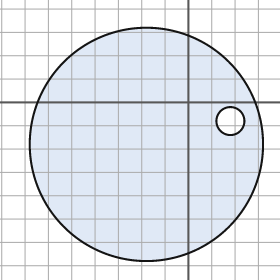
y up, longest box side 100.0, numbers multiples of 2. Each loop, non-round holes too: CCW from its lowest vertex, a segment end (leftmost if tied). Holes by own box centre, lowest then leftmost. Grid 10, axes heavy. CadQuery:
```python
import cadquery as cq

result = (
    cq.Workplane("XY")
    .moveTo(-18.0, -18.0)
    .circle(50.0)
    .moveTo(18.0, -8.0)
    .circle(6.0)
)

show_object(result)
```